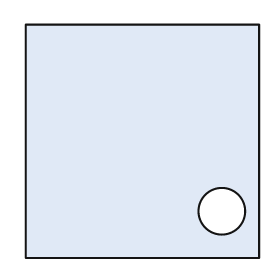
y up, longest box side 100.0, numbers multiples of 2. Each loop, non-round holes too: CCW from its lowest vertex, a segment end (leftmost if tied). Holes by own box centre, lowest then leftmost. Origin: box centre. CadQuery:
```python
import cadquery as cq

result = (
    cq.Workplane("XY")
    .moveTo(-50.0, -50.0)
    .lineTo(50.0, -50.0)
    .lineTo(50.0, 50.0)
    .lineTo(-50.0, 50.0)
    .close()
    .moveTo(34.0, -30.0)
    .circle(10.0)
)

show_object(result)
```